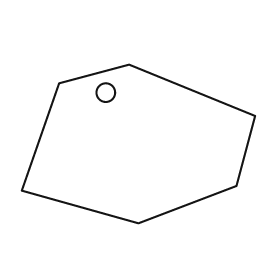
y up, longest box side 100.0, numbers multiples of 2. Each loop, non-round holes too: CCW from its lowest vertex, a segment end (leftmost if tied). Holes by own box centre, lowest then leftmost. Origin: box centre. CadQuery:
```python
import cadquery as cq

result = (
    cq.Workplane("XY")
    .moveTo(0.0, -34.0)
    .lineTo(42.0, -18.0)
    .lineTo(50.0, 12.0)
    .lineTo(-4.0, 34.0)
    .lineTo(-34.0, 26.0)
    .lineTo(-50.0, -20.0)
    .close()
    .moveTo(-14.0, 22.0)
    .circle(4.0)
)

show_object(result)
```